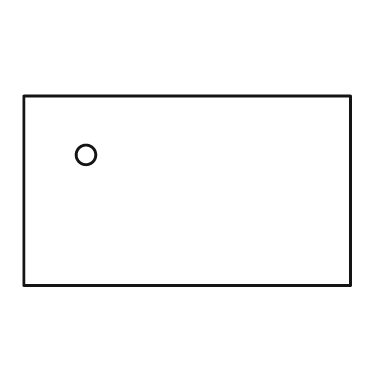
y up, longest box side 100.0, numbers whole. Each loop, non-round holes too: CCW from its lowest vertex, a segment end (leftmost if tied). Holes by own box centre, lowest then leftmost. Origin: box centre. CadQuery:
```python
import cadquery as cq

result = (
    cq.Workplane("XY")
    .moveTo(-50.0, -29.0)
    .lineTo(50.0, -29.0)
    .lineTo(50.0, 29.0)
    .lineTo(-50.0, 29.0)
    .close()
    .moveTo(-31.0, 11.0)
    .circle(3.0)
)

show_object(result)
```